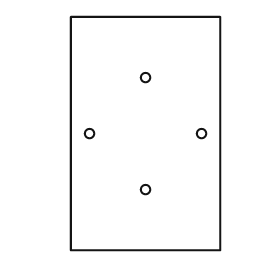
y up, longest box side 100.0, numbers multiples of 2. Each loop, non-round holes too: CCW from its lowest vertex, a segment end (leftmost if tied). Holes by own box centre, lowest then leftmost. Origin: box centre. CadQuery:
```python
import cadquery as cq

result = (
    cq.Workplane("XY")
    .moveTo(-32.0, -50.0)
    .lineTo(32.0, -50.0)
    .lineTo(32.0, 50.0)
    .lineTo(-32.0, 50.0)
    .close()
    .moveTo(0.0, -24.0)
    .circle(2.0)
    .moveTo(-24.0, 0.0)
    .circle(2.0)
    .moveTo(24.0, 0.0)
    .circle(2.0)
    .moveTo(0.0, 24.0)
    .circle(2.0)
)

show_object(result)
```